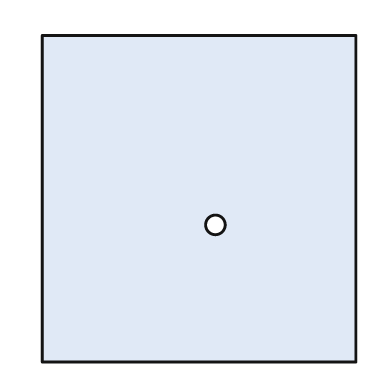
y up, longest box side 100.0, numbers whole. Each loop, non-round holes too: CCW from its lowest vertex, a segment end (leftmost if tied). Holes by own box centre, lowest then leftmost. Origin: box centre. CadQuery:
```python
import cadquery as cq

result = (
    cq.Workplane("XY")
    .moveTo(-48.0, -50.0)
    .lineTo(48.0, -50.0)
    .lineTo(48.0, 50.0)
    .lineTo(-48.0, 50.0)
    .close()
    .moveTo(5.0, -8.0)
    .circle(3.0)
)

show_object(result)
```